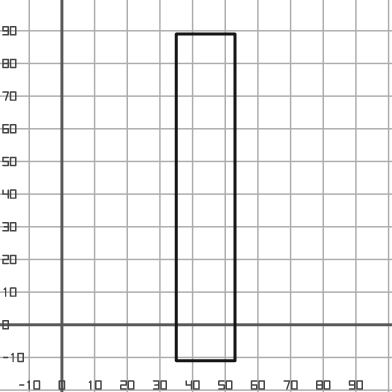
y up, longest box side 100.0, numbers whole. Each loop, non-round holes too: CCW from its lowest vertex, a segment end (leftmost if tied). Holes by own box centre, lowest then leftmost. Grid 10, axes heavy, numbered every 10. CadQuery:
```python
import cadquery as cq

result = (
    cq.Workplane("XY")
    .moveTo(35.0, -11.0)
    .lineTo(53.0, -11.0)
    .lineTo(53.0, 89.0)
    .lineTo(35.0, 89.0)
    .close()
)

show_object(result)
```